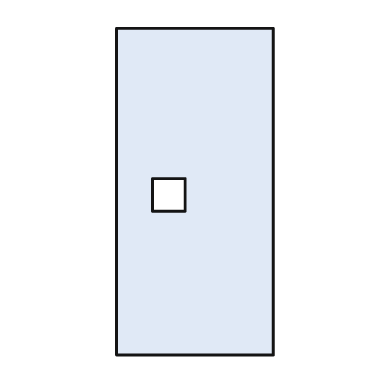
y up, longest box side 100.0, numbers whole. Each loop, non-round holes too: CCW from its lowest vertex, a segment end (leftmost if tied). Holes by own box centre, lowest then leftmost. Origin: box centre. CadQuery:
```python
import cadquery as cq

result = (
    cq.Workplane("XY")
    .moveTo(-24.0, -50.0)
    .lineTo(24.0, -50.0)
    .lineTo(24.0, 50.0)
    .lineTo(-24.0, 50.0)
    .close()
    .moveTo(-13.0, -6.0)
    .lineTo(-3.0, -6.0)
    .lineTo(-3.0, 4.0)
    .lineTo(-13.0, 4.0)
    .close()
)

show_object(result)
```